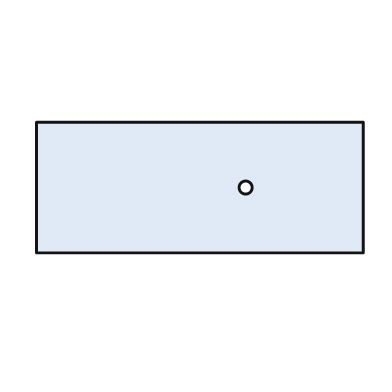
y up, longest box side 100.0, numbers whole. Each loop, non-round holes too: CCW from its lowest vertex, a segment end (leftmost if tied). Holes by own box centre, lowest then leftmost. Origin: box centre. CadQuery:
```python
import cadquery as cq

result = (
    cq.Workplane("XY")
    .moveTo(-50.0, -20.0)
    .lineTo(50.0, -20.0)
    .lineTo(50.0, 20.0)
    .lineTo(-50.0, 20.0)
    .close()
    .moveTo(14.0, 0.0)
    .circle(2.0)
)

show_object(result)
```